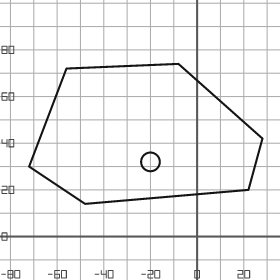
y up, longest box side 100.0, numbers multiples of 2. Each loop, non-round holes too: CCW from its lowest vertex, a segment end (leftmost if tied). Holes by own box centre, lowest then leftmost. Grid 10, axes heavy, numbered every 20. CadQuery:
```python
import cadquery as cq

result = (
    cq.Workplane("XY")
    .moveTo(-48.0, 14.0)
    .lineTo(22.0, 20.0)
    .lineTo(28.0, 42.0)
    .lineTo(-8.0, 74.0)
    .lineTo(-56.0, 72.0)
    .lineTo(-72.0, 30.0)
    .close()
    .moveTo(-20.0, 32.0)
    .circle(4.0)
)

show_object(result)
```